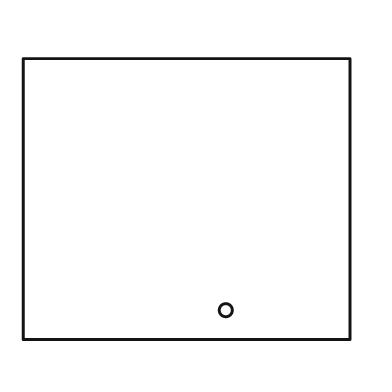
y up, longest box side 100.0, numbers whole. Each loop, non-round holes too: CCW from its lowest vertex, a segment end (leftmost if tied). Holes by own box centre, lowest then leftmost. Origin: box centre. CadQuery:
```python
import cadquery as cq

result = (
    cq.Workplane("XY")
    .moveTo(-50.0, -43.0)
    .lineTo(50.0, -43.0)
    .lineTo(50.0, 43.0)
    .lineTo(-50.0, 43.0)
    .close()
    .moveTo(12.0, -34.0)
    .circle(2.0)
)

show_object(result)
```